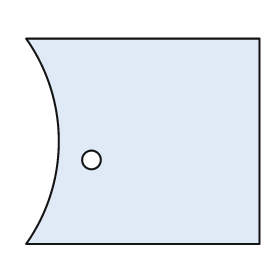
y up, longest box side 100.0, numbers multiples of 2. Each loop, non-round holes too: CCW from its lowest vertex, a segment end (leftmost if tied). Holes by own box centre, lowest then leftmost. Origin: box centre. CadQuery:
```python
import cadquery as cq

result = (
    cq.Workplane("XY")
    .moveTo(-50.0, -44.0)
    .lineTo(50.0, -44.0)
    .lineTo(50.0, 44.0)
    .lineTo(-50.0, 44.0)
    .threePointArc((-36.0, 0.0), (-50.0, -44.0))
    .close()
    .moveTo(-22.0, -8.0)
    .circle(4.0)
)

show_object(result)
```